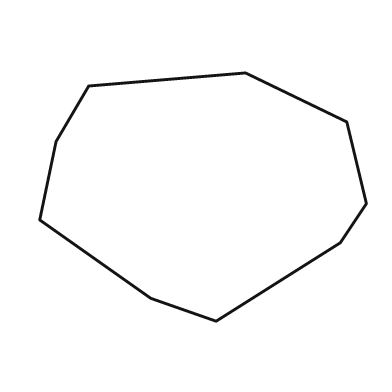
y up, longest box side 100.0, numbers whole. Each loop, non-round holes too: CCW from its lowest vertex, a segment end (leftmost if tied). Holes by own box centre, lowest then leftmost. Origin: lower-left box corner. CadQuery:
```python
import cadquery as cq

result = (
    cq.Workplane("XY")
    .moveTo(54.0, 0.0)
    .lineTo(92.0, 24.0)
    .lineTo(100.0, 36.0)
    .lineTo(94.0, 61.0)
    .lineTo(63.0, 76.0)
    .lineTo(15.0, 72.0)
    .lineTo(5.0, 55.0)
    .lineTo(0.0, 31.0)
    .lineTo(34.0, 7.0)
    .close()
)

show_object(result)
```